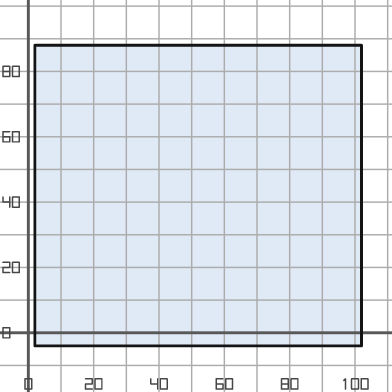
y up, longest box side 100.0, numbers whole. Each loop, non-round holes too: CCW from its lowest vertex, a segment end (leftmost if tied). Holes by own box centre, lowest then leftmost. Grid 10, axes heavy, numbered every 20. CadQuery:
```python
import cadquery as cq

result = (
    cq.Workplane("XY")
    .moveTo(2.0, -4.0)
    .lineTo(102.0, -4.0)
    .lineTo(102.0, 88.0)
    .lineTo(2.0, 88.0)
    .close()
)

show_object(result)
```